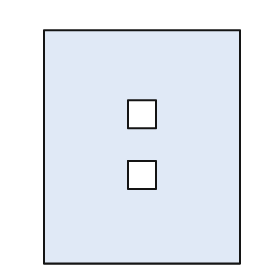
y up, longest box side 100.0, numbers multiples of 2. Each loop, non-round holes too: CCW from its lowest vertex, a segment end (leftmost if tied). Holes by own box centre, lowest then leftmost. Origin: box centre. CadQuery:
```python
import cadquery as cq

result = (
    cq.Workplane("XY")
    .moveTo(-42.0, -50.0)
    .lineTo(42.0, -50.0)
    .lineTo(42.0, 50.0)
    .lineTo(-42.0, 50.0)
    .close()
    .moveTo(-6.0, -18.0)
    .lineTo(6.0, -18.0)
    .lineTo(6.0, -6.0)
    .lineTo(-6.0, -6.0)
    .close()
    .moveTo(-6.0, 8.0)
    .lineTo(6.0, 8.0)
    .lineTo(6.0, 20.0)
    .lineTo(-6.0, 20.0)
    .close()
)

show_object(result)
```